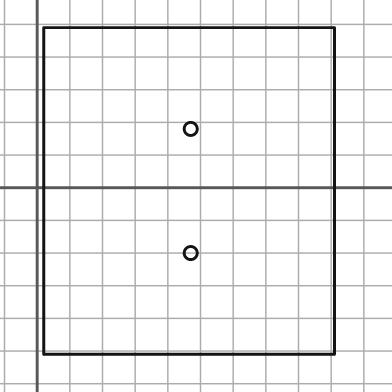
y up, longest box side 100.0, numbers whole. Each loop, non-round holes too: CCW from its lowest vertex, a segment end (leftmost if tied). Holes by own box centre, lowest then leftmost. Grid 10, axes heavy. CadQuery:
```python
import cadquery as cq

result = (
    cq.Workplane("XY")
    .moveTo(2.0, -51.0)
    .lineTo(91.0, -51.0)
    .lineTo(91.0, 49.0)
    .lineTo(2.0, 49.0)
    .close()
    .moveTo(47.0, -20.0)
    .circle(2.0)
    .moveTo(47.0, 18.0)
    .circle(2.0)
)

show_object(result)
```